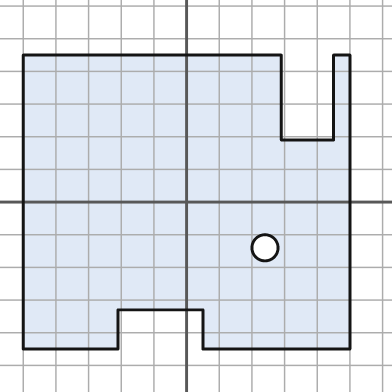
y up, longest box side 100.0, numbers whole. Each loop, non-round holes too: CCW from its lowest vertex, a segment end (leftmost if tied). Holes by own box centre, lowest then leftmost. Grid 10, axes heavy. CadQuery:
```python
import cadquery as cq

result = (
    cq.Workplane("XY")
    .moveTo(-50.0, -45.0)
    .lineTo(-21.0, -45.0)
    .lineTo(-21.0, -33.0)
    .lineTo(5.0, -33.0)
    .lineTo(5.0, -45.0)
    .lineTo(50.0, -45.0)
    .lineTo(50.0, 45.0)
    .lineTo(45.0, 45.0)
    .lineTo(45.0, 19.0)
    .lineTo(29.0, 19.0)
    .lineTo(29.0, 45.0)
    .lineTo(-50.0, 45.0)
    .close()
    .moveTo(24.0, -14.0)
    .circle(4.0)
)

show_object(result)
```